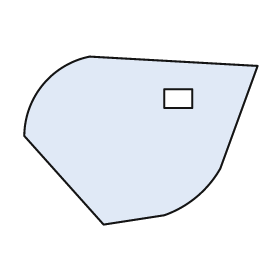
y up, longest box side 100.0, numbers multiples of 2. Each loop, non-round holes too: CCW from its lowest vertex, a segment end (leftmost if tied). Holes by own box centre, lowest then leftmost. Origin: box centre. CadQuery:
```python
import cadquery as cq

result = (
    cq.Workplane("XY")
    .moveTo(-16.0, -36.0)
    .lineTo(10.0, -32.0)
    .threePointArc((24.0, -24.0), (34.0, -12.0))
    .lineTo(50.0, 32.0)
    .lineTo(-22.0, 36.0)
    .threePointArc((-42.0, 24.0), (-50.0, 2.0))
    .close()
    .moveTo(10.0, 14.0)
    .lineTo(22.0, 14.0)
    .lineTo(22.0, 22.0)
    .lineTo(10.0, 22.0)
    .close()
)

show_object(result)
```